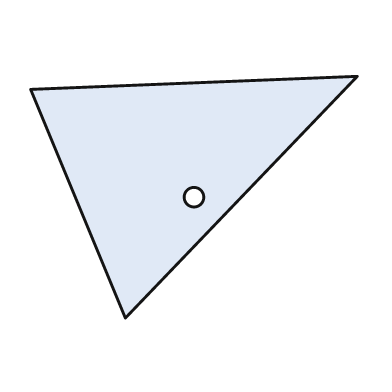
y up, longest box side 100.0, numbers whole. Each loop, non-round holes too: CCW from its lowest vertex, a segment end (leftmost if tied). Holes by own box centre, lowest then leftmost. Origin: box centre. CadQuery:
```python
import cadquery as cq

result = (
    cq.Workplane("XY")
    .moveTo(-21.0, -37.0)
    .lineTo(50.0, 37.0)
    .lineTo(-50.0, 33.0)
    .close()
    .moveTo(0.0, 0.0)
    .circle(3.0)
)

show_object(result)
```